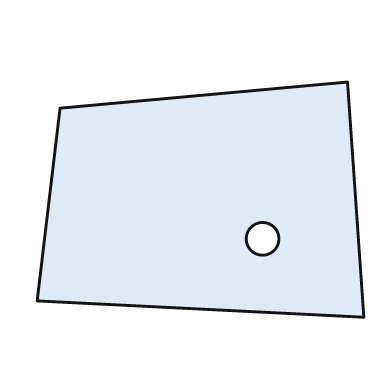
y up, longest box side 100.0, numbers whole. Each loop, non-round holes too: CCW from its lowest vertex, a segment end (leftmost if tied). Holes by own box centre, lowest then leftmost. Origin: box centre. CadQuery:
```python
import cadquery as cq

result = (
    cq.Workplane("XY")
    .moveTo(50.0, -36.0)
    .lineTo(45.0, 36.0)
    .lineTo(-43.0, 28.0)
    .lineTo(-50.0, -31.0)
    .close()
    .moveTo(19.0, -12.0)
    .circle(5.0)
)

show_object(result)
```